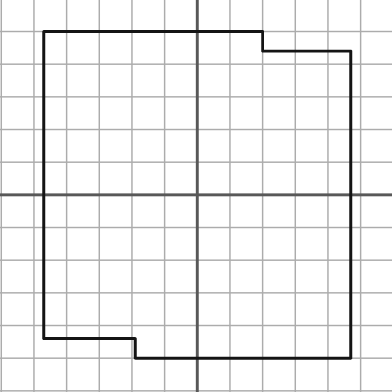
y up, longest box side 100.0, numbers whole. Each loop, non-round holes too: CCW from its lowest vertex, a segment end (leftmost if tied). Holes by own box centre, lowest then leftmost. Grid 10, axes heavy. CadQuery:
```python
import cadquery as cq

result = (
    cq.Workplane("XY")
    .moveTo(-19.0, -50.0)
    .lineTo(47.0, -50.0)
    .lineTo(47.0, 44.0)
    .lineTo(20.0, 44.0)
    .lineTo(20.0, 50.0)
    .lineTo(-47.0, 50.0)
    .lineTo(-47.0, -44.0)
    .lineTo(-19.0, -44.0)
    .close()
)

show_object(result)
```